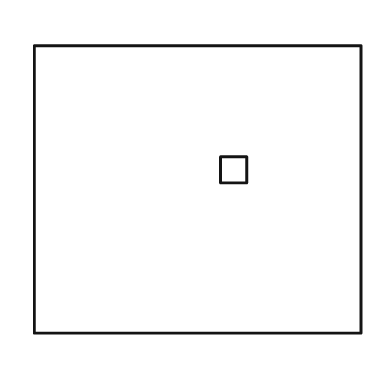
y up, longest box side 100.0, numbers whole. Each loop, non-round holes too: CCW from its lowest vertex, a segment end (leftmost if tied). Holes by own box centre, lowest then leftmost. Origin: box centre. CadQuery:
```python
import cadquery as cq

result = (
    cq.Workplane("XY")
    .moveTo(-50.0, -44.0)
    .lineTo(50.0, -44.0)
    .lineTo(50.0, 44.0)
    .lineTo(-50.0, 44.0)
    .close()
    .moveTo(7.0, 2.0)
    .lineTo(15.0, 2.0)
    .lineTo(15.0, 10.0)
    .lineTo(7.0, 10.0)
    .close()
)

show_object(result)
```